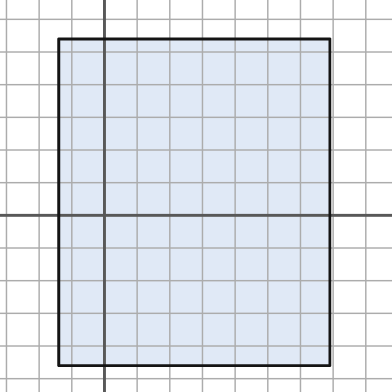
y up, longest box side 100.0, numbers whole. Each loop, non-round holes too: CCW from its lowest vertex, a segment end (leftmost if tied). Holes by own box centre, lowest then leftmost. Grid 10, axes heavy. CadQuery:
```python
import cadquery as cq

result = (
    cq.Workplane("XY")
    .moveTo(-14.0, -46.0)
    .lineTo(69.0, -46.0)
    .lineTo(69.0, 54.0)
    .lineTo(-14.0, 54.0)
    .close()
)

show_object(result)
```